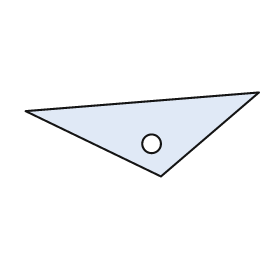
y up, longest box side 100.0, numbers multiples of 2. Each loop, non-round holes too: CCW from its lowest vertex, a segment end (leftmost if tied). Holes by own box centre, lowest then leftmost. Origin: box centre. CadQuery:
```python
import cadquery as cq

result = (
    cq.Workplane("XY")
    .moveTo(8.0, -18.0)
    .lineTo(50.0, 18.0)
    .lineTo(-50.0, 10.0)
    .close()
    .moveTo(4.0, -4.0)
    .circle(4.0)
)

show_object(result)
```